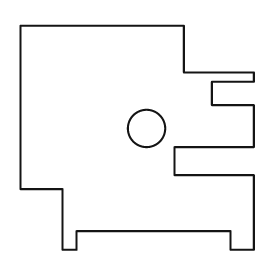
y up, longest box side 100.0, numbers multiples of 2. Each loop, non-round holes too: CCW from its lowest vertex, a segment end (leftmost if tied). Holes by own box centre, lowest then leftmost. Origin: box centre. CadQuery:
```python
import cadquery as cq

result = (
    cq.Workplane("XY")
    .moveTo(-32.0, -48.0)
    .lineTo(-26.0, -48.0)
    .lineTo(-26.0, -40.0)
    .lineTo(40.0, -40.0)
    .lineTo(40.0, -48.0)
    .lineTo(50.0, -48.0)
    .lineTo(50.0, -16.0)
    .lineTo(16.0, -16.0)
    .lineTo(16.0, -4.0)
    .lineTo(50.0, -4.0)
    .lineTo(50.0, 14.0)
    .lineTo(32.0, 14.0)
    .lineTo(32.0, 24.0)
    .lineTo(50.0, 24.0)
    .lineTo(50.0, 28.0)
    .lineTo(20.0, 28.0)
    .lineTo(20.0, 48.0)
    .lineTo(-50.0, 48.0)
    .lineTo(-50.0, -22.0)
    .lineTo(-32.0, -22.0)
    .close()
    .moveTo(4.0, 4.0)
    .circle(8.0)
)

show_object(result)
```